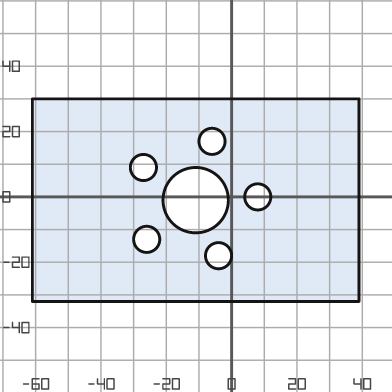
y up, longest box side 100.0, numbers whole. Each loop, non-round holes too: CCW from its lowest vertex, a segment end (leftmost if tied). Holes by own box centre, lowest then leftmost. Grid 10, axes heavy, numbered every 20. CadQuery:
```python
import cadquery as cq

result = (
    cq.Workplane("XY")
    .moveTo(-61.0, -32.0)
    .lineTo(39.0, -32.0)
    .lineTo(39.0, 30.0)
    .lineTo(-61.0, 30.0)
    .close()
    .moveTo(-4.0, -18.0)
    .circle(4.0)
    .moveTo(-26.0, -13.0)
    .circle(4.0)
    .moveTo(-11.0, -1.0)
    .circle(10.0)
    .moveTo(8.0, 0.0)
    .circle(4.0)
    .moveTo(-27.0, 9.0)
    .circle(4.0)
    .moveTo(-6.0, 17.0)
    .circle(4.0)
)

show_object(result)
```